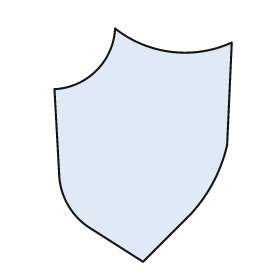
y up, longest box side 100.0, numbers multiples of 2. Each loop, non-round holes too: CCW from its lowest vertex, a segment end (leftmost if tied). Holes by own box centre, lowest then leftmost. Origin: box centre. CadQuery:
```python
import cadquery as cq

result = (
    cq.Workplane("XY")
    .moveTo(0.0, -50.0)
    .lineTo(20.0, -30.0)
    .threePointArc((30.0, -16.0), (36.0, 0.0))
    .lineTo(38.0, 44.0)
    .threePointArc((12.0, 40.0), (-12.0, 50.0))
    .threePointArc((-20.0, 32.0), (-38.0, 24.0))
    .lineTo(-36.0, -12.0)
    .threePointArc((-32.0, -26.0), (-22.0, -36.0))
    .close()
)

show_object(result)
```